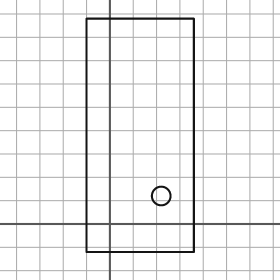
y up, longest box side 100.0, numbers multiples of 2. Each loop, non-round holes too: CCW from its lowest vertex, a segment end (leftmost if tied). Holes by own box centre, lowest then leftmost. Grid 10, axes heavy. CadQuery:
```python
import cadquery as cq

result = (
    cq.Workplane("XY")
    .moveTo(-10.0, -12.0)
    .lineTo(36.0, -12.0)
    .lineTo(36.0, 88.0)
    .lineTo(-10.0, 88.0)
    .close()
    .moveTo(22.0, 12.0)
    .circle(4.0)
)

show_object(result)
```